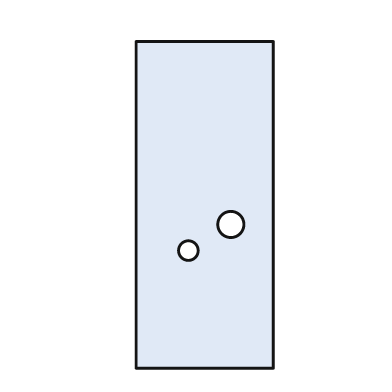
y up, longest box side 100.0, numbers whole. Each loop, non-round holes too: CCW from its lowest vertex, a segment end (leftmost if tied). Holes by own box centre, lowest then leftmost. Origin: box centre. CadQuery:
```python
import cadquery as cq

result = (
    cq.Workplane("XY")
    .moveTo(-21.0, -50.0)
    .lineTo(21.0, -50.0)
    .lineTo(21.0, 50.0)
    .lineTo(-21.0, 50.0)
    .close()
    .moveTo(-5.0, -14.0)
    .circle(3.0)
    .moveTo(8.0, -6.0)
    .circle(4.0)
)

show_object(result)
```